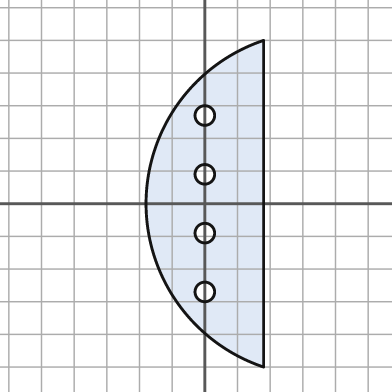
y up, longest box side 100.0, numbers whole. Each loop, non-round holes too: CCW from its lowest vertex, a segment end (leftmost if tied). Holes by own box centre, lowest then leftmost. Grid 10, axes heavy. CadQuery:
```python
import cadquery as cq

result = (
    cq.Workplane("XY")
    .moveTo(18.0, -50.0)
    .lineTo(18.0, 50.0)
    .threePointArc((-18.0, 0.0), (18.0, -50.0))
    .close()
    .moveTo(0.0, -27.0)
    .circle(3.0)
    .moveTo(0.0, -9.0)
    .circle(3.0)
    .moveTo(0.0, 9.0)
    .circle(3.0)
    .moveTo(0.0, 27.0)
    .circle(3.0)
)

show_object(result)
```